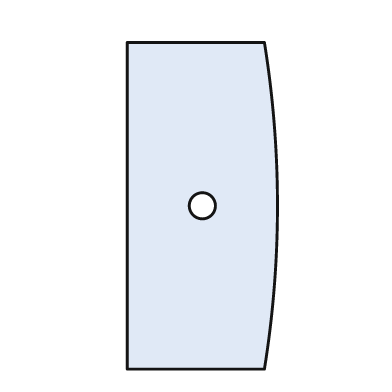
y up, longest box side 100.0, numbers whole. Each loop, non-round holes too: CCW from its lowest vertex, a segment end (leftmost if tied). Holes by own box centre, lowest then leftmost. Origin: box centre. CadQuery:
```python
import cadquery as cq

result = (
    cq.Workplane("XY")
    .moveTo(-23.0, -50.0)
    .lineTo(19.0, -50.0)
    .threePointArc((23.0, 0.0), (19.0, 50.0))
    .lineTo(-23.0, 50.0)
    .close()
    .moveTo(0.0, 0.0)
    .circle(4.0)
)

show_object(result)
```